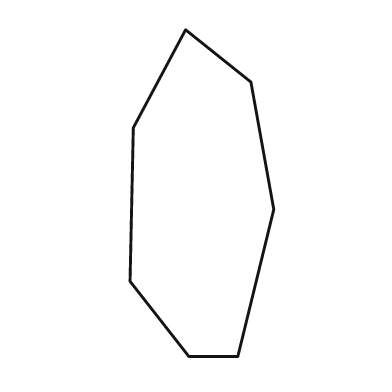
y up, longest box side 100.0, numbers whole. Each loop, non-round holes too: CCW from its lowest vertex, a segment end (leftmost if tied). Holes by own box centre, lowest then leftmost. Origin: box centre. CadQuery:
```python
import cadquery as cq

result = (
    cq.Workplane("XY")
    .moveTo(-4.0, -50.0)
    .lineTo(11.0, -50.0)
    .lineTo(22.0, -5.0)
    .lineTo(15.0, 34.0)
    .lineTo(-5.0, 50.0)
    .lineTo(-21.0, 20.0)
    .lineTo(-22.0, -27.0)
    .close()
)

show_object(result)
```